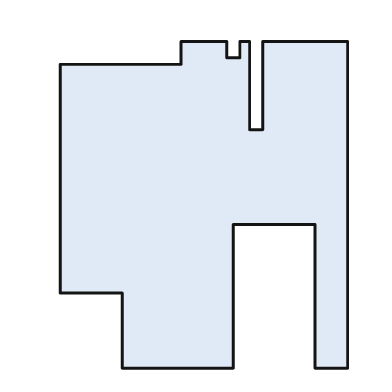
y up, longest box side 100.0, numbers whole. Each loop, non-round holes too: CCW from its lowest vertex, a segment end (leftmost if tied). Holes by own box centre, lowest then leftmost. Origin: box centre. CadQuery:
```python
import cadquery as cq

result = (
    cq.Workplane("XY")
    .moveTo(-25.0, -50.0)
    .lineTo(9.0, -50.0)
    .lineTo(9.0, -6.0)
    .lineTo(34.0, -6.0)
    .lineTo(34.0, -50.0)
    .lineTo(44.0, -50.0)
    .lineTo(44.0, 50.0)
    .lineTo(18.0, 50.0)
    .lineTo(18.0, 23.0)
    .lineTo(14.0, 23.0)
    .lineTo(14.0, 50.0)
    .lineTo(11.0, 50.0)
    .lineTo(11.0, 45.0)
    .lineTo(7.0, 45.0)
    .lineTo(7.0, 50.0)
    .lineTo(-7.0, 50.0)
    .lineTo(-7.0, 43.0)
    .lineTo(-44.0, 43.0)
    .lineTo(-44.0, -27.0)
    .lineTo(-25.0, -27.0)
    .close()
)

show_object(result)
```